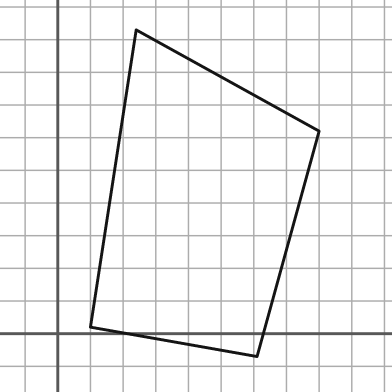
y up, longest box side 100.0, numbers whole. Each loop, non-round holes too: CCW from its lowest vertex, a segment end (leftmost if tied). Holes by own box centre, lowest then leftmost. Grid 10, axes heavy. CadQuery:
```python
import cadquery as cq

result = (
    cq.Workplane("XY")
    .moveTo(61.0, -7.0)
    .lineTo(80.0, 62.0)
    .lineTo(24.0, 93.0)
    .lineTo(10.0, 2.0)
    .close()
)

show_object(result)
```